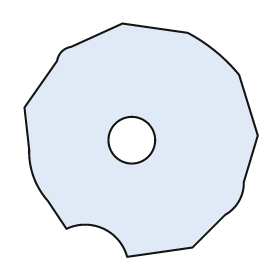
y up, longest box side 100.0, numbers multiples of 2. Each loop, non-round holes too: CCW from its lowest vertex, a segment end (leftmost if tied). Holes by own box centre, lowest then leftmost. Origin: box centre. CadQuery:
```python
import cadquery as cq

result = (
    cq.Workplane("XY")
    .moveTo(-6.0, -50.0)
    .lineTo(22.0, -46.0)
    .lineTo(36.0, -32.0)
    .threePointArc((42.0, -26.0), (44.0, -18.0))
    .lineTo(50.0, 2.0)
    .lineTo(42.0, 28.0)
    .threePointArc((32.0, 38.0), (20.0, 46.0))
    .lineTo(-8.0, 50.0)
    .lineTo(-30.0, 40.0)
    .threePointArc((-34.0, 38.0), (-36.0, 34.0))
    .lineTo(-50.0, 14.0)
    .lineTo(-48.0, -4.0)
    .threePointArc((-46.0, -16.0), (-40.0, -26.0))
    .lineTo(-32.0, -38.0)
    .threePointArc((-16.0, -38.0), (-6.0, -50.0))
    .close()
    .moveTo(-4.0, 0.0)
    .circle(10.0)
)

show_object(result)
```